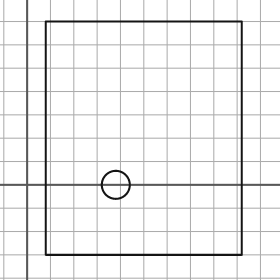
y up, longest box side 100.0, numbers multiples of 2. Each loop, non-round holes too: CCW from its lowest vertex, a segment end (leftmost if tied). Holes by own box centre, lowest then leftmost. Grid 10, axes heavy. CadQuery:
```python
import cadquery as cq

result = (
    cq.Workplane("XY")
    .moveTo(8.0, -30.0)
    .lineTo(92.0, -30.0)
    .lineTo(92.0, 70.0)
    .lineTo(8.0, 70.0)
    .close()
    .moveTo(38.0, 0.0)
    .circle(6.0)
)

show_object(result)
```